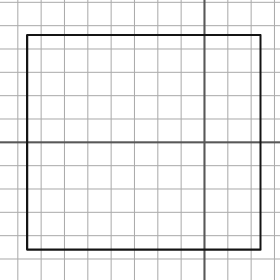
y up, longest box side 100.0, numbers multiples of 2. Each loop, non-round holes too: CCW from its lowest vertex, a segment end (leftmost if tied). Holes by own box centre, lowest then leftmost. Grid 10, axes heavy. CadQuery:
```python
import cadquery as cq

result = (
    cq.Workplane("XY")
    .moveTo(-76.0, -46.0)
    .lineTo(24.0, -46.0)
    .lineTo(24.0, 46.0)
    .lineTo(-76.0, 46.0)
    .close()
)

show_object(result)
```